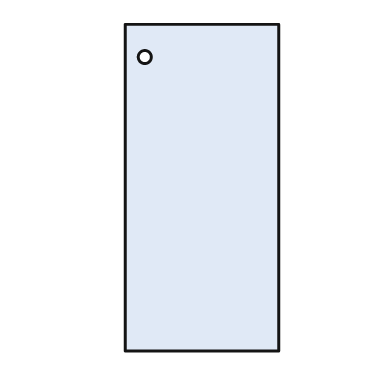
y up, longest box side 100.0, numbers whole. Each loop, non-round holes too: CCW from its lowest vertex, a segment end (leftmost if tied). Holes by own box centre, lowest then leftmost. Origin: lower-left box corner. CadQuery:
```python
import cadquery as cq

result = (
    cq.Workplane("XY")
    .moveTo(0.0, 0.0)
    .lineTo(47.0, 0.0)
    .lineTo(47.0, 100.0)
    .lineTo(0.0, 100.0)
    .close()
    .moveTo(6.0, 90.0)
    .circle(2.0)
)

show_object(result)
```